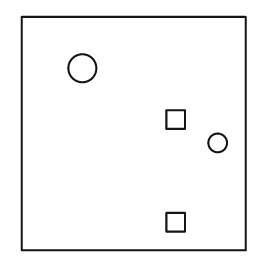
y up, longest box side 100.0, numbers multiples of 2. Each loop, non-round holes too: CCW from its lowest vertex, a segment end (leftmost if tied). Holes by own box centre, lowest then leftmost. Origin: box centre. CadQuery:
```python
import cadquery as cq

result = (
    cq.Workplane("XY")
    .moveTo(-48.0, -50.0)
    .lineTo(48.0, -50.0)
    .lineTo(48.0, 50.0)
    .lineTo(-48.0, 50.0)
    .close()
    .moveTo(14.0, -42.0)
    .lineTo(22.0, -42.0)
    .lineTo(22.0, -34.0)
    .lineTo(14.0, -34.0)
    .close()
    .moveTo(36.0, -4.0)
    .circle(4.0)
    .moveTo(14.0, 2.0)
    .lineTo(22.0, 2.0)
    .lineTo(22.0, 10.0)
    .lineTo(14.0, 10.0)
    .close()
    .moveTo(-22.0, 28.0)
    .circle(6.0)
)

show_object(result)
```